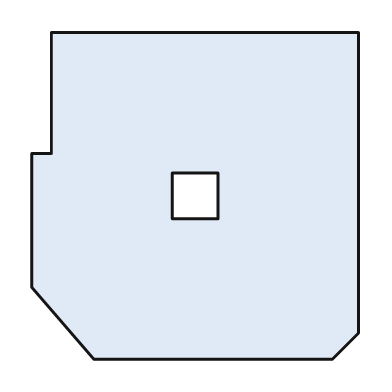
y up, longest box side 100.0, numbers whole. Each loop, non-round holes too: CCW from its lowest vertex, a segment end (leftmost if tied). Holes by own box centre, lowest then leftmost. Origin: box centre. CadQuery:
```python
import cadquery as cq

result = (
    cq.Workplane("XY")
    .moveTo(-31.0, -50.0)
    .lineTo(42.0, -50.0)
    .lineTo(50.0, -42.0)
    .lineTo(50.0, 50.0)
    .lineTo(-44.0, 50.0)
    .lineTo(-44.0, 13.0)
    .lineTo(-50.0, 13.0)
    .lineTo(-50.0, -28.0)
    .close()
    .moveTo(-7.0, -7.0)
    .lineTo(7.0, -7.0)
    .lineTo(7.0, 7.0)
    .lineTo(-7.0, 7.0)
    .close()
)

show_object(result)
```